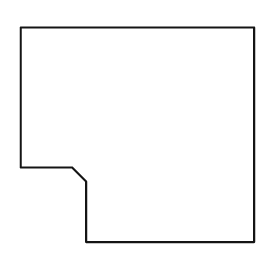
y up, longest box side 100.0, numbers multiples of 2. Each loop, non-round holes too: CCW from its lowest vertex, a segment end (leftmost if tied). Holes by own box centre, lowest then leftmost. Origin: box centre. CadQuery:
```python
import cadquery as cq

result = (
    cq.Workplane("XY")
    .moveTo(-22.0, -46.0)
    .lineTo(50.0, -46.0)
    .lineTo(50.0, 46.0)
    .lineTo(-50.0, 46.0)
    .lineTo(-50.0, -14.0)
    .lineTo(-28.0, -14.0)
    .lineTo(-22.0, -20.0)
    .close()
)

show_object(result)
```